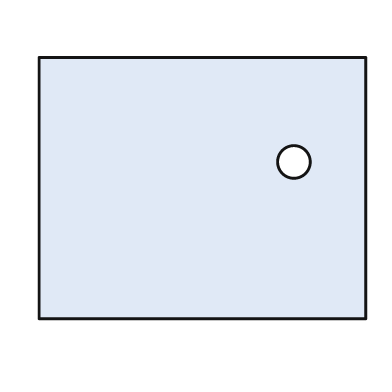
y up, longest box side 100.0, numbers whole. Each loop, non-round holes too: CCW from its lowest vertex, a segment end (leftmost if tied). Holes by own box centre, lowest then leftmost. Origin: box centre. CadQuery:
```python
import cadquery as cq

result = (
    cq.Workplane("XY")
    .moveTo(-50.0, -40.0)
    .lineTo(50.0, -40.0)
    .lineTo(50.0, 40.0)
    .lineTo(-50.0, 40.0)
    .close()
    .moveTo(28.0, 8.0)
    .circle(5.0)
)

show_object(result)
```